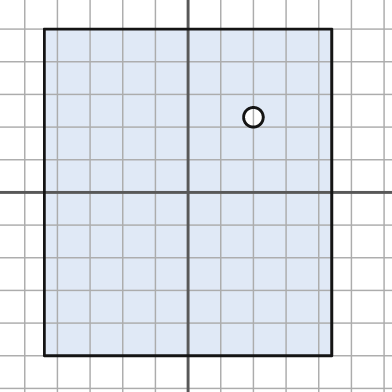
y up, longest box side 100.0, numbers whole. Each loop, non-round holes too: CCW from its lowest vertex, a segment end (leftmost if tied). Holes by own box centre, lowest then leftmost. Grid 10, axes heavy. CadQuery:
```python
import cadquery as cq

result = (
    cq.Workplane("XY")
    .moveTo(-44.0, -50.0)
    .lineTo(44.0, -50.0)
    .lineTo(44.0, 50.0)
    .lineTo(-44.0, 50.0)
    .close()
    .moveTo(20.0, 23.0)
    .circle(3.0)
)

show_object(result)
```